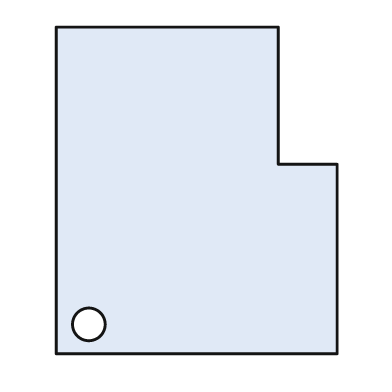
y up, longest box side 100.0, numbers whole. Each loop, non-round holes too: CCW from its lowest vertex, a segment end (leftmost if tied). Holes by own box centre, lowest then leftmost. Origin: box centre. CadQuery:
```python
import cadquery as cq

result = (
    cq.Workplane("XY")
    .moveTo(-43.0, -50.0)
    .lineTo(43.0, -50.0)
    .lineTo(43.0, 8.0)
    .lineTo(25.0, 8.0)
    .lineTo(25.0, 50.0)
    .lineTo(-43.0, 50.0)
    .close()
    .moveTo(-33.0, -41.0)
    .circle(5.0)
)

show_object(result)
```